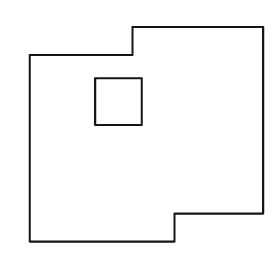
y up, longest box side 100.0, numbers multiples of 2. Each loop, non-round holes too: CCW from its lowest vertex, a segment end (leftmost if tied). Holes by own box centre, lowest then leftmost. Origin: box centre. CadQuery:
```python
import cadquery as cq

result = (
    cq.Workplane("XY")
    .moveTo(-50.0, -46.0)
    .lineTo(12.0, -46.0)
    .lineTo(12.0, -34.0)
    .lineTo(50.0, -34.0)
    .lineTo(50.0, 46.0)
    .lineTo(-6.0, 46.0)
    .lineTo(-6.0, 34.0)
    .lineTo(-50.0, 34.0)
    .close()
    .moveTo(-22.0, 4.0)
    .lineTo(-2.0, 4.0)
    .lineTo(-2.0, 24.0)
    .lineTo(-22.0, 24.0)
    .close()
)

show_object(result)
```